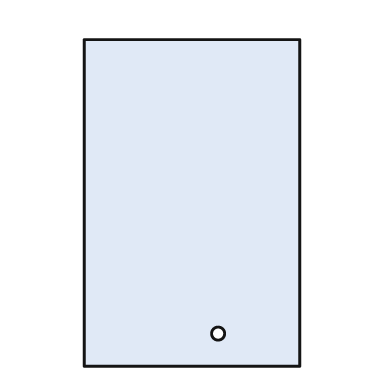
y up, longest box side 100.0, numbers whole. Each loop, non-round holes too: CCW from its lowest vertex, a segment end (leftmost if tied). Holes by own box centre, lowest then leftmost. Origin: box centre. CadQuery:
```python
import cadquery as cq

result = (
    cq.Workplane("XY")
    .moveTo(-33.0, -50.0)
    .lineTo(33.0, -50.0)
    .lineTo(33.0, 50.0)
    .lineTo(-33.0, 50.0)
    .close()
    .moveTo(8.0, -40.0)
    .circle(2.0)
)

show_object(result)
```